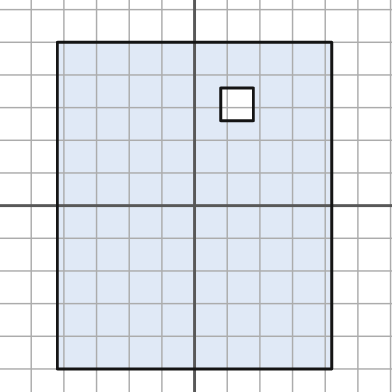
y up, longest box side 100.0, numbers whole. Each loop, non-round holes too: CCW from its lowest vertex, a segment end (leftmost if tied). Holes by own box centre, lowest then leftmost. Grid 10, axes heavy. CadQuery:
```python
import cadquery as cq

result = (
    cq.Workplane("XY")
    .moveTo(-42.0, -50.0)
    .lineTo(42.0, -50.0)
    .lineTo(42.0, 50.0)
    .lineTo(-42.0, 50.0)
    .close()
    .moveTo(8.0, 26.0)
    .lineTo(18.0, 26.0)
    .lineTo(18.0, 36.0)
    .lineTo(8.0, 36.0)
    .close()
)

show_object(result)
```